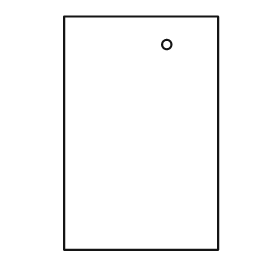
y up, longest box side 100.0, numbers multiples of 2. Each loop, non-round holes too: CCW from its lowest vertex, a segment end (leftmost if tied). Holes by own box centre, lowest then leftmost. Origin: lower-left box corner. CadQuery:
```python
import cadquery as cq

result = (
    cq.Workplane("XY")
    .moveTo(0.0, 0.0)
    .lineTo(66.0, 0.0)
    .lineTo(66.0, 100.0)
    .lineTo(0.0, 100.0)
    .close()
    .moveTo(44.0, 88.0)
    .circle(2.0)
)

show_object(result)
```